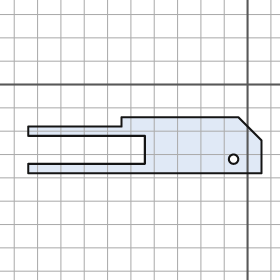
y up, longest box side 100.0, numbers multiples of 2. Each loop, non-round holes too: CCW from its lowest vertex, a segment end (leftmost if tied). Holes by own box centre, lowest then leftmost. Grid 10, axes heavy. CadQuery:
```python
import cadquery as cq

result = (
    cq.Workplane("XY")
    .moveTo(-94.0, -38.0)
    .lineTo(6.0, -38.0)
    .lineTo(6.0, -24.0)
    .lineTo(-4.0, -14.0)
    .lineTo(-54.0, -14.0)
    .lineTo(-54.0, -18.0)
    .lineTo(-94.0, -18.0)
    .lineTo(-94.0, -22.0)
    .lineTo(-44.0, -22.0)
    .lineTo(-44.0, -34.0)
    .lineTo(-94.0, -34.0)
    .close()
    .moveTo(-6.0, -32.0)
    .circle(2.0)
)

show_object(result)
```